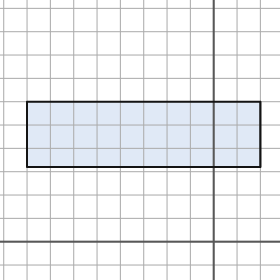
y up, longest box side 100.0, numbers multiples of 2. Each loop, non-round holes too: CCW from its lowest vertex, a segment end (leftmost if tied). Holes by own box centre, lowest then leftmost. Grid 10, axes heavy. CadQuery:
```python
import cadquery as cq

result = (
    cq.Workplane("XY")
    .moveTo(-80.0, 32.0)
    .lineTo(20.0, 32.0)
    .lineTo(20.0, 60.0)
    .lineTo(-80.0, 60.0)
    .close()
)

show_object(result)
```